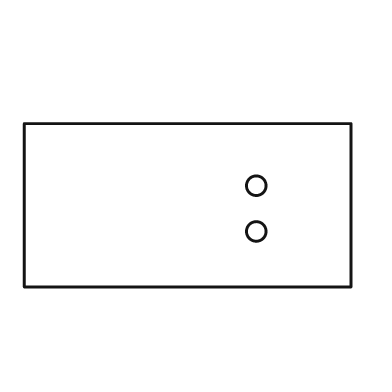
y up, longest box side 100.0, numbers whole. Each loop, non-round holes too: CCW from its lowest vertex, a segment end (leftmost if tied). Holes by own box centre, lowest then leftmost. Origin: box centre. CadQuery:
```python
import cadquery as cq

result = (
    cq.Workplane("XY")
    .moveTo(-50.0, -25.0)
    .lineTo(50.0, -25.0)
    .lineTo(50.0, 25.0)
    .lineTo(-50.0, 25.0)
    .close()
    .moveTo(21.0, -8.0)
    .circle(3.0)
    .moveTo(21.0, 6.0)
    .circle(3.0)
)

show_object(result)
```